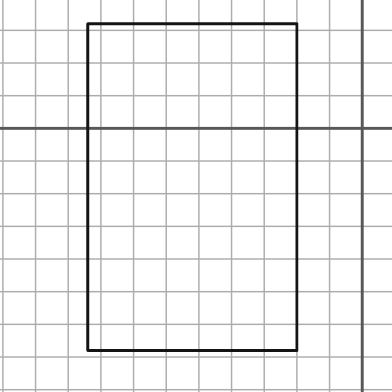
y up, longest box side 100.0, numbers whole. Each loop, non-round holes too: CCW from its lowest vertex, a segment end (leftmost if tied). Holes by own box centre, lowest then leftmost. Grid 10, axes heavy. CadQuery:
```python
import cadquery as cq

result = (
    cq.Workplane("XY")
    .moveTo(-84.0, -68.0)
    .lineTo(-20.0, -68.0)
    .lineTo(-20.0, 32.0)
    .lineTo(-84.0, 32.0)
    .close()
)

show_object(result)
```